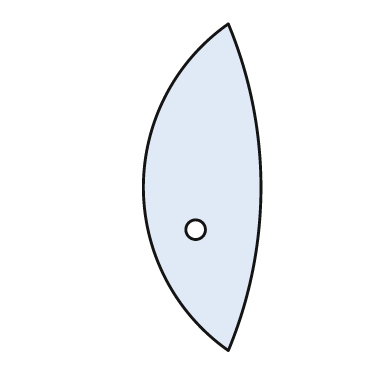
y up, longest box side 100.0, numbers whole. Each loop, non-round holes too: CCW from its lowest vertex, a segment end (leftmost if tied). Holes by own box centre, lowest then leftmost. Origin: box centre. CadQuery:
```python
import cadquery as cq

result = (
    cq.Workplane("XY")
    .moveTo(8.0, -50.0)
    .threePointArc((18.0, 0.0), (8.0, 50.0))
    .threePointArc((-18.0, 0.0), (8.0, -50.0))
    .close()
    .moveTo(-2.0, -13.0)
    .circle(3.0)
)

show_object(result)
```